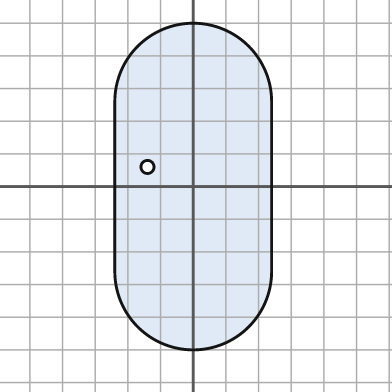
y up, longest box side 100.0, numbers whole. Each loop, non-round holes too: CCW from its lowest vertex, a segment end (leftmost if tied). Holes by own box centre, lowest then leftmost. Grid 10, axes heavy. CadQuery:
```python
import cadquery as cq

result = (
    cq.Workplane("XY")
    .moveTo(-24.0, -26.0)
    .threePointArc((0.0, -50.0), (24.0, -26.0))
    .lineTo(24.0, 26.0)
    .threePointArc((0.0, 50.0), (-24.0, 26.0))
    .close()
    .moveTo(-14.0, 6.0)
    .circle(2.0)
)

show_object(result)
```